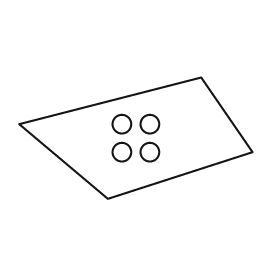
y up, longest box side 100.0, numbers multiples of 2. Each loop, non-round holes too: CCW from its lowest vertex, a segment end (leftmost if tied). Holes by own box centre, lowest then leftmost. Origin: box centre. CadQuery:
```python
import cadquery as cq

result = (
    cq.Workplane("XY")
    .moveTo(-12.0, -26.0)
    .lineTo(50.0, -6.0)
    .lineTo(28.0, 26.0)
    .lineTo(-50.0, 6.0)
    .close()
    .moveTo(-6.0, -6.0)
    .circle(4.0)
    .moveTo(6.0, -6.0)
    .circle(4.0)
    .moveTo(-6.0, 6.0)
    .circle(4.0)
    .moveTo(6.0, 6.0)
    .circle(4.0)
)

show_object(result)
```